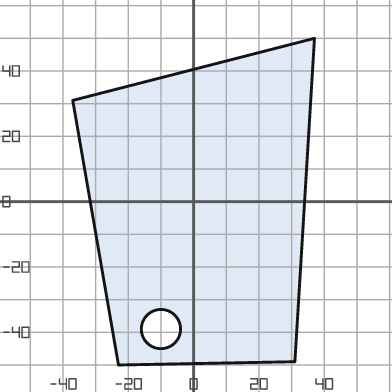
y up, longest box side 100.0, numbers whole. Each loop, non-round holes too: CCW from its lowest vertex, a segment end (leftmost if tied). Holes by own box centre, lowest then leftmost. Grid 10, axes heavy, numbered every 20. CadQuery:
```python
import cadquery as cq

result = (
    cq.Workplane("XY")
    .moveTo(-23.0, -50.0)
    .lineTo(31.0, -49.0)
    .lineTo(37.0, 50.0)
    .lineTo(-37.0, 31.0)
    .close()
    .moveTo(-10.0, -39.0)
    .circle(6.0)
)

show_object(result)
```